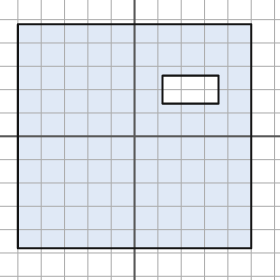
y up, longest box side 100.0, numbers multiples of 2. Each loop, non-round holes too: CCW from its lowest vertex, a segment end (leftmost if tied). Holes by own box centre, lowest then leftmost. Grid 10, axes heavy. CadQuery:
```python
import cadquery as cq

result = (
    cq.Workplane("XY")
    .moveTo(-50.0, -48.0)
    .lineTo(50.0, -48.0)
    .lineTo(50.0, 48.0)
    .lineTo(-50.0, 48.0)
    .close()
    .moveTo(12.0, 14.0)
    .lineTo(36.0, 14.0)
    .lineTo(36.0, 26.0)
    .lineTo(12.0, 26.0)
    .close()
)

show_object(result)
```